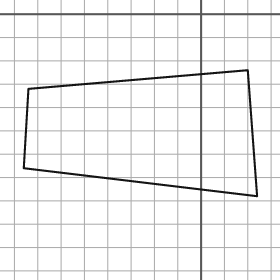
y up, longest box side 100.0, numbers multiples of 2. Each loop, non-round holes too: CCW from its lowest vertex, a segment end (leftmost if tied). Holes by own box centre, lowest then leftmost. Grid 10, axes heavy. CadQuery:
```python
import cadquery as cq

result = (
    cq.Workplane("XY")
    .moveTo(24.0, -78.0)
    .lineTo(20.0, -24.0)
    .lineTo(-74.0, -32.0)
    .lineTo(-76.0, -66.0)
    .close()
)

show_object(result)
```